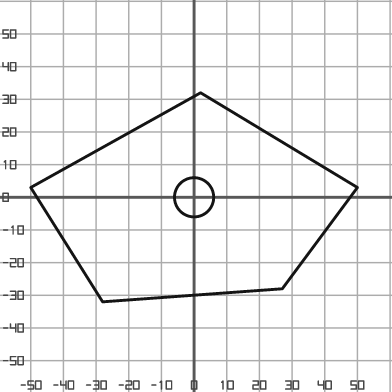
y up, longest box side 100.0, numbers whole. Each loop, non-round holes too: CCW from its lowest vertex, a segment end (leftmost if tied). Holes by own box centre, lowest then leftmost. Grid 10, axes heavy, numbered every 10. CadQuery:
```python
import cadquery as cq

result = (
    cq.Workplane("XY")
    .moveTo(-28.0, -32.0)
    .lineTo(27.0, -28.0)
    .lineTo(50.0, 3.0)
    .lineTo(2.0, 32.0)
    .lineTo(-50.0, 3.0)
    .close()
    .moveTo(0.0, 0.0)
    .circle(6.0)
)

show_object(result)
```